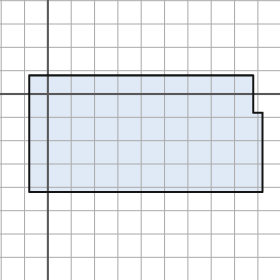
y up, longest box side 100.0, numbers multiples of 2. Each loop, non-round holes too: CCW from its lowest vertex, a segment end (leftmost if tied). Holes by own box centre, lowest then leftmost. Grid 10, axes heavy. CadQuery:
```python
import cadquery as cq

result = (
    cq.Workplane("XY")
    .moveTo(-8.0, -42.0)
    .lineTo(92.0, -42.0)
    .lineTo(92.0, -8.0)
    .lineTo(88.0, -8.0)
    .lineTo(88.0, 8.0)
    .lineTo(-8.0, 8.0)
    .close()
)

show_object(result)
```